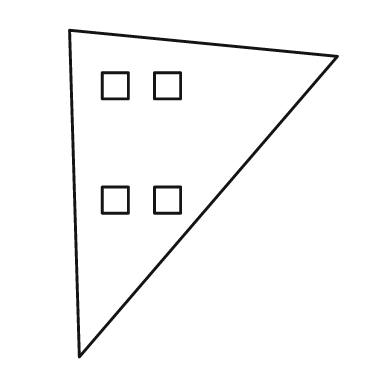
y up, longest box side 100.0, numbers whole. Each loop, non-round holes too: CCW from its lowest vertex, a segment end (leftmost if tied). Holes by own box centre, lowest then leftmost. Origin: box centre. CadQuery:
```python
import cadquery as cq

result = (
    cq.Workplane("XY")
    .moveTo(-38.0, -50.0)
    .lineTo(41.0, 42.0)
    .lineTo(-41.0, 50.0)
    .close()
    .moveTo(-31.0, -6.0)
    .lineTo(-23.0, -6.0)
    .lineTo(-23.0, 2.0)
    .lineTo(-31.0, 2.0)
    .close()
    .moveTo(-15.0, -6.0)
    .lineTo(-7.0, -6.0)
    .lineTo(-7.0, 2.0)
    .lineTo(-15.0, 2.0)
    .close()
    .moveTo(-31.0, 29.0)
    .lineTo(-23.0, 29.0)
    .lineTo(-23.0, 37.0)
    .lineTo(-31.0, 37.0)
    .close()
    .moveTo(-15.0, 29.0)
    .lineTo(-7.0, 29.0)
    .lineTo(-7.0, 37.0)
    .lineTo(-15.0, 37.0)
    .close()
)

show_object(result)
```